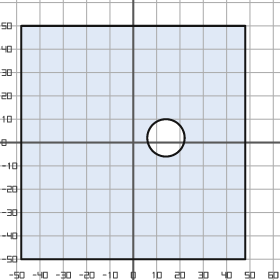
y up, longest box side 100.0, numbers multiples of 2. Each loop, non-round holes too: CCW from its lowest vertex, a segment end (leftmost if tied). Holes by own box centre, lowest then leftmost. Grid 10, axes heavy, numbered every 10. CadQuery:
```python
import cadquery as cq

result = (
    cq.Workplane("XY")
    .moveTo(-48.0, -50.0)
    .lineTo(48.0, -50.0)
    .lineTo(48.0, 50.0)
    .lineTo(-48.0, 50.0)
    .close()
    .moveTo(14.0, 2.0)
    .circle(8.0)
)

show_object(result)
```